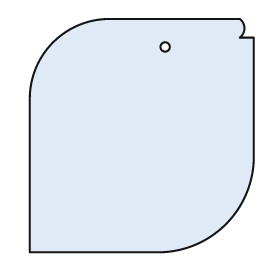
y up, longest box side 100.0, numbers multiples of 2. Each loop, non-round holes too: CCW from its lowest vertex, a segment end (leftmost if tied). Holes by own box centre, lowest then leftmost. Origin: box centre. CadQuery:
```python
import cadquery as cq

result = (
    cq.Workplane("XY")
    .moveTo(-48.0, -50.0)
    .lineTo(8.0, -50.0)
    .threePointArc((36.0, -38.0), (48.0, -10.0))
    .lineTo(48.0, 42.0)
    .lineTo(42.0, 42.0)
    .threePointArc((44.0, 46.0), (42.0, 50.0))
    .lineTo(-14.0, 50.0)
    .threePointArc((-38.0, 40.0), (-48.0, 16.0))
    .close()
    .moveTo(10.0, 38.0)
    .circle(2.0)
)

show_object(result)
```